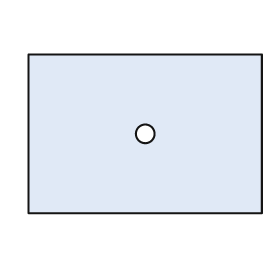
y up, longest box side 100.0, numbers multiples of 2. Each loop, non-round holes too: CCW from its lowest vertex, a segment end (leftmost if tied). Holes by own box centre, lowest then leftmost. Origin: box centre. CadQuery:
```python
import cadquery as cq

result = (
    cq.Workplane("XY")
    .moveTo(-50.0, -34.0)
    .lineTo(50.0, -34.0)
    .lineTo(50.0, 34.0)
    .lineTo(-50.0, 34.0)
    .close()
    .moveTo(0.0, 0.0)
    .circle(4.0)
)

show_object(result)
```